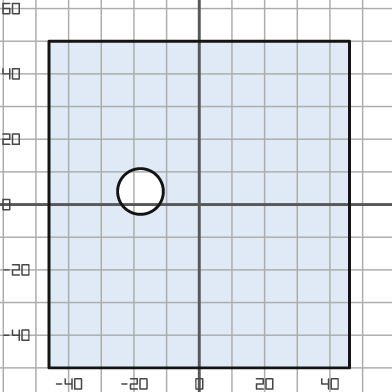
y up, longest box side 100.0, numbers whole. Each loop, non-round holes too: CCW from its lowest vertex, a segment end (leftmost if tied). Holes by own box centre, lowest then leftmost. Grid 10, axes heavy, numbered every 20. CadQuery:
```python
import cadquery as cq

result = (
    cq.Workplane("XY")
    .moveTo(-46.0, -50.0)
    .lineTo(46.0, -50.0)
    .lineTo(46.0, 50.0)
    .lineTo(-46.0, 50.0)
    .close()
    .moveTo(-18.0, 4.0)
    .circle(7.0)
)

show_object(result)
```